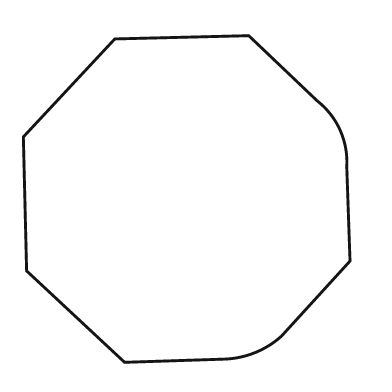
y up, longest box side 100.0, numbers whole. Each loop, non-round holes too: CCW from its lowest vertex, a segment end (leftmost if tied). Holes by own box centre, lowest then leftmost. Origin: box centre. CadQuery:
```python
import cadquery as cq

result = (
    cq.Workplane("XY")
    .moveTo(-19.0, -50.0)
    .lineTo(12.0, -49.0)
    .threePointArc((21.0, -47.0), (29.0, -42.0))
    .lineTo(50.0, -19.0)
    .lineTo(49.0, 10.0)
    .threePointArc((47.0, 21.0), (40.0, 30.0))
    .lineTo(19.0, 50.0)
    .lineTo(-22.0, 49.0)
    .lineTo(-50.0, 19.0)
    .lineTo(-49.0, -22.0)
    .close()
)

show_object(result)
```